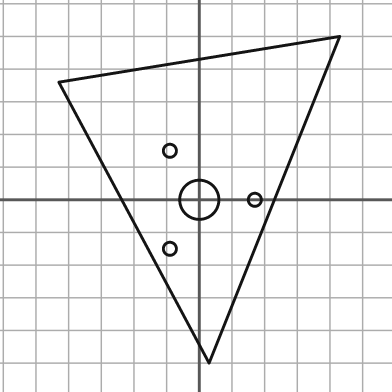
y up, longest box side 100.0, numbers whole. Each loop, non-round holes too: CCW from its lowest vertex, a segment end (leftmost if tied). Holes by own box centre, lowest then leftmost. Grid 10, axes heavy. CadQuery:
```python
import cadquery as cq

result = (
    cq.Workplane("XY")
    .moveTo(3.0, -50.0)
    .lineTo(43.0, 50.0)
    .lineTo(-43.0, 36.0)
    .close()
    .moveTo(-9.0, -15.0)
    .circle(2.0)
    .moveTo(0.0, 0.0)
    .circle(6.0)
    .moveTo(17.0, 0.0)
    .circle(2.0)
    .moveTo(-9.0, 15.0)
    .circle(2.0)
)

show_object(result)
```